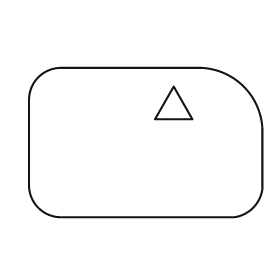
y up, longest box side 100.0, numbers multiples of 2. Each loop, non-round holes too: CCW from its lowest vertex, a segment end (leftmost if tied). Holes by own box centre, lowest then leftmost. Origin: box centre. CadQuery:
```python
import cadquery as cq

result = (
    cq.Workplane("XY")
    .moveTo(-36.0, -32.0)
    .lineTo(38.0, -32.0)
    .threePointArc((46.0, -28.0), (50.0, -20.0))
    .lineTo(50.0, 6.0)
    .threePointArc((42.0, 24.0), (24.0, 32.0))
    .lineTo(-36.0, 32.0)
    .threePointArc((-46.0, 28.0), (-50.0, 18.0))
    .lineTo(-50.0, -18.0)
    .threePointArc((-46.0, -28.0), (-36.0, -32.0))
    .close()
    .moveTo(4.0, 10.0)
    .lineTo(20.0, 10.0)
    .lineTo(12.0, 24.0)
    .close()
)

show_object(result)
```